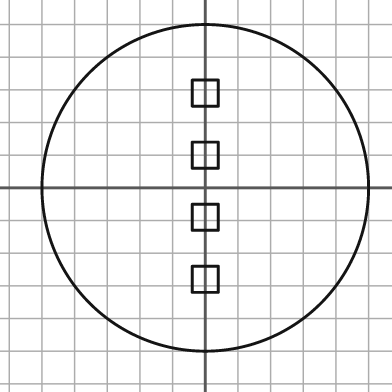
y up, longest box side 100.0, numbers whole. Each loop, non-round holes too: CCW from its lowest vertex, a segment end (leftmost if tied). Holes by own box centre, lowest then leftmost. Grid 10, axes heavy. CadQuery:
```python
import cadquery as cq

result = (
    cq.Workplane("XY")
    .moveTo(0.0, 0.0)
    .circle(50.0)
    .moveTo(-4.0, -32.0)
    .lineTo(4.0, -32.0)
    .lineTo(4.0, -24.0)
    .lineTo(-4.0, -24.0)
    .close()
    .moveTo(-4.0, -13.0)
    .lineTo(4.0, -13.0)
    .lineTo(4.0, -5.0)
    .lineTo(-4.0, -5.0)
    .close()
    .moveTo(-4.0, 6.0)
    .lineTo(4.0, 6.0)
    .lineTo(4.0, 14.0)
    .lineTo(-4.0, 14.0)
    .close()
    .moveTo(-4.0, 25.0)
    .lineTo(4.0, 25.0)
    .lineTo(4.0, 33.0)
    .lineTo(-4.0, 33.0)
    .close()
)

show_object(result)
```